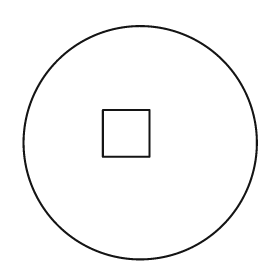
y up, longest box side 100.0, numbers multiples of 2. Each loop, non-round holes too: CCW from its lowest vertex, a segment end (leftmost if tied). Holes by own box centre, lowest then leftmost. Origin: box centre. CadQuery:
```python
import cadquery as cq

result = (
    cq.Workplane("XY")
    .moveTo(0.0, 0.0)
    .circle(50.0)
    .moveTo(-16.0, -6.0)
    .lineTo(4.0, -6.0)
    .lineTo(4.0, 14.0)
    .lineTo(-16.0, 14.0)
    .close()
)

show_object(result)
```